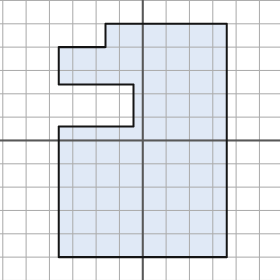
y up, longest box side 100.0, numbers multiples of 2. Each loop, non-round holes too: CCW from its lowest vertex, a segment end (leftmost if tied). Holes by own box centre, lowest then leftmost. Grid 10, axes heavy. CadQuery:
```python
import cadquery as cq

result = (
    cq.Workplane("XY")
    .moveTo(-36.0, -50.0)
    .lineTo(36.0, -50.0)
    .lineTo(36.0, 50.0)
    .lineTo(-16.0, 50.0)
    .lineTo(-16.0, 40.0)
    .lineTo(-36.0, 40.0)
    .lineTo(-36.0, 24.0)
    .lineTo(-4.0, 24.0)
    .lineTo(-4.0, 6.0)
    .lineTo(-36.0, 6.0)
    .close()
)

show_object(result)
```